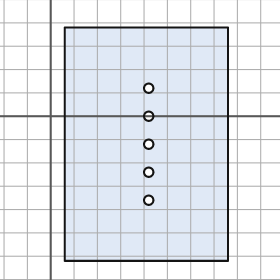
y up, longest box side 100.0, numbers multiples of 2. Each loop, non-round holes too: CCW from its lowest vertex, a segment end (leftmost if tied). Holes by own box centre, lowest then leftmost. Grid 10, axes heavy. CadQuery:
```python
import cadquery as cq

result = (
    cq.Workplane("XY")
    .moveTo(6.0, -62.0)
    .lineTo(76.0, -62.0)
    .lineTo(76.0, 38.0)
    .lineTo(6.0, 38.0)
    .close()
    .moveTo(42.0, -36.0)
    .circle(2.0)
    .moveTo(42.0, -24.0)
    .circle(2.0)
    .moveTo(42.0, -12.0)
    .circle(2.0)
    .moveTo(42.0, 0.0)
    .circle(2.0)
    .moveTo(42.0, 12.0)
    .circle(2.0)
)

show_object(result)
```